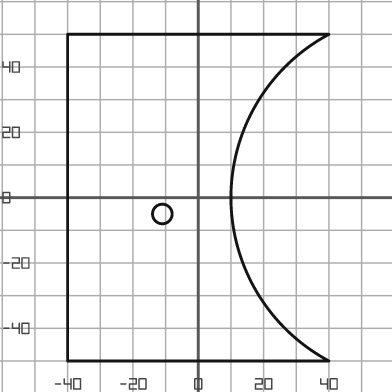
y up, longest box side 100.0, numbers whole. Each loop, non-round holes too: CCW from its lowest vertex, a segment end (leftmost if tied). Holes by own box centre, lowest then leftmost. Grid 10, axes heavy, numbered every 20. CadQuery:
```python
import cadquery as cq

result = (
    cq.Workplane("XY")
    .moveTo(-40.0, -50.0)
    .lineTo(40.0, -50.0)
    .threePointArc((10.0, 0.0), (40.0, 50.0))
    .lineTo(-40.0, 50.0)
    .close()
    .moveTo(-11.0, -5.0)
    .circle(3.0)
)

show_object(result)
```